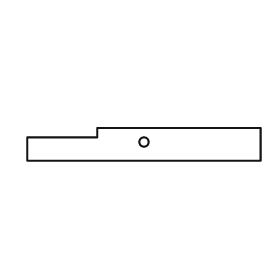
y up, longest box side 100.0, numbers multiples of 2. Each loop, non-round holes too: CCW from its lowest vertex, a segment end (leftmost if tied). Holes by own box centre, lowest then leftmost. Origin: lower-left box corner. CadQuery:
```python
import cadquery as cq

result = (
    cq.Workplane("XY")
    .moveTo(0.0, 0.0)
    .lineTo(100.0, 0.0)
    .lineTo(100.0, 14.0)
    .lineTo(30.0, 14.0)
    .lineTo(30.0, 10.0)
    .lineTo(0.0, 10.0)
    .close()
    .moveTo(50.0, 8.0)
    .circle(2.0)
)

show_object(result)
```